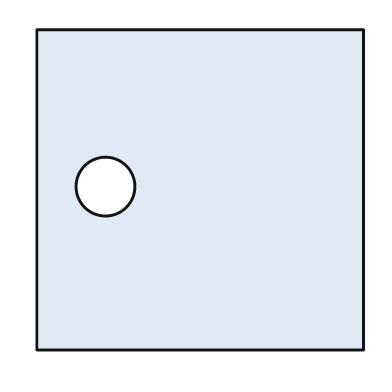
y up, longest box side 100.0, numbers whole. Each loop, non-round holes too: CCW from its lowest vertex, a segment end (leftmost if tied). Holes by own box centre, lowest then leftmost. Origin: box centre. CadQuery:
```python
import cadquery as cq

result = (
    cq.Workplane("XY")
    .moveTo(-50.0, -49.0)
    .lineTo(50.0, -49.0)
    .lineTo(50.0, 49.0)
    .lineTo(-50.0, 49.0)
    .close()
    .moveTo(-29.0, 1.0)
    .circle(9.0)
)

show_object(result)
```